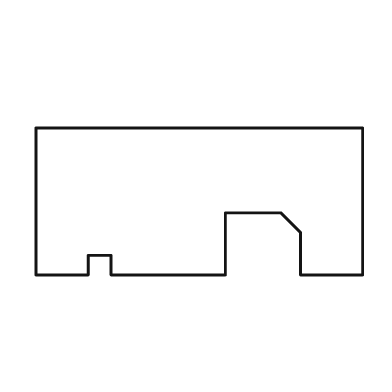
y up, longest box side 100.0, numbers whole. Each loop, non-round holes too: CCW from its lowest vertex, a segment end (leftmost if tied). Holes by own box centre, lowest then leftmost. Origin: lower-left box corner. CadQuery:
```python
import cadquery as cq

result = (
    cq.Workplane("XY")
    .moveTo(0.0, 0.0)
    .lineTo(16.0, 0.0)
    .lineTo(16.0, 6.0)
    .lineTo(23.0, 6.0)
    .lineTo(23.0, 0.0)
    .lineTo(58.0, 0.0)
    .lineTo(58.0, 19.0)
    .lineTo(75.0, 19.0)
    .lineTo(81.0, 13.0)
    .lineTo(81.0, 0.0)
    .lineTo(100.0, 0.0)
    .lineTo(100.0, 45.0)
    .lineTo(0.0, 45.0)
    .close()
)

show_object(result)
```